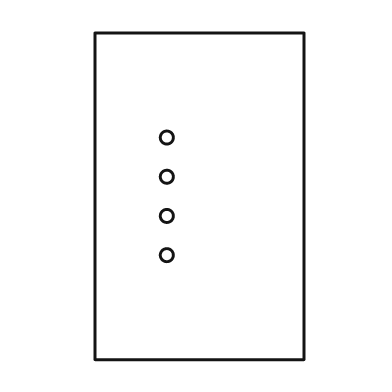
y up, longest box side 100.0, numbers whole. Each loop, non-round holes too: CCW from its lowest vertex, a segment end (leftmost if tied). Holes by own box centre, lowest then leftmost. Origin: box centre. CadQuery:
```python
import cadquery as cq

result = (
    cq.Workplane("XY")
    .moveTo(-32.0, -50.0)
    .lineTo(32.0, -50.0)
    .lineTo(32.0, 50.0)
    .lineTo(-32.0, 50.0)
    .close()
    .moveTo(-10.0, -18.0)
    .circle(2.0)
    .moveTo(-10.0, -6.0)
    .circle(2.0)
    .moveTo(-10.0, 6.0)
    .circle(2.0)
    .moveTo(-10.0, 18.0)
    .circle(2.0)
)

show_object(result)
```